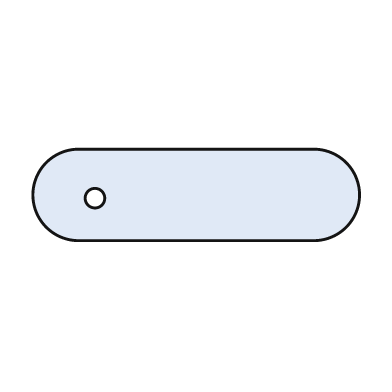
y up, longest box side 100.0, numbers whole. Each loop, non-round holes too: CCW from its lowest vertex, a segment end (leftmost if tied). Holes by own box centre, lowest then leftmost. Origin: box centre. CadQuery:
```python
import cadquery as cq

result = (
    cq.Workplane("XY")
    .moveTo(-36.0, -14.0)
    .lineTo(36.0, -14.0)
    .threePointArc((50.0, 0.0), (36.0, 14.0))
    .lineTo(-36.0, 14.0)
    .threePointArc((-50.0, 0.0), (-36.0, -14.0))
    .close()
    .moveTo(-31.0, -1.0)
    .circle(3.0)
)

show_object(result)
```